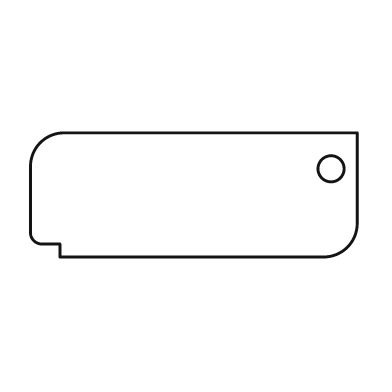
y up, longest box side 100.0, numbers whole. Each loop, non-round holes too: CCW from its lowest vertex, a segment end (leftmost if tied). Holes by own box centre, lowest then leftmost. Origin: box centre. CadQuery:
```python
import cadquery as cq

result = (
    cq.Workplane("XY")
    .moveTo(-41.0, -19.0)
    .lineTo(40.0, -19.0)
    .threePointArc((47.0, -16.0), (50.0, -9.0))
    .lineTo(50.0, 19.0)
    .lineTo(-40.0, 19.0)
    .threePointArc((-47.0, 16.0), (-50.0, 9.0))
    .lineTo(-50.0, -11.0)
    .threePointArc((-49.0, -14.0), (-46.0, -15.0))
    .lineTo(-41.0, -15.0)
    .close()
    .moveTo(42.0, 8.0)
    .circle(4.0)
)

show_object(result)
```